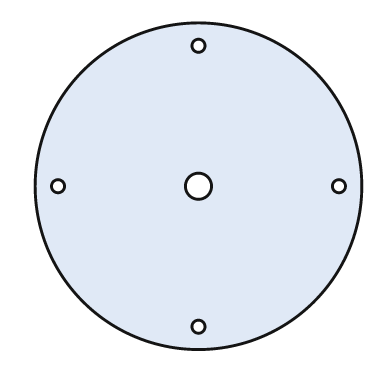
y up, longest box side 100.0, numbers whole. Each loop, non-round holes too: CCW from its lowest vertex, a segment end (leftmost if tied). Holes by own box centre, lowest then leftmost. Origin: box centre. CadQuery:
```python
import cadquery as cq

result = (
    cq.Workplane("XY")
    .moveTo(0.0, 0.0)
    .circle(50.0)
    .moveTo(0.0, -43.0)
    .circle(2.0)
    .moveTo(-43.0, 0.0)
    .circle(2.0)
    .moveTo(0.0, 0.0)
    .circle(4.0)
    .moveTo(43.0, 0.0)
    .circle(2.0)
    .moveTo(0.0, 43.0)
    .circle(2.0)
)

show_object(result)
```